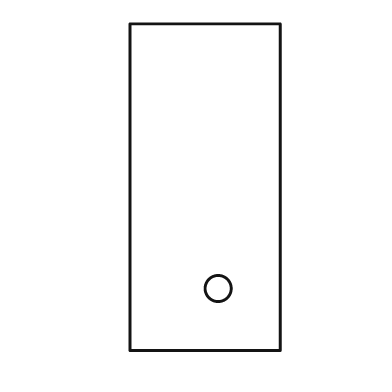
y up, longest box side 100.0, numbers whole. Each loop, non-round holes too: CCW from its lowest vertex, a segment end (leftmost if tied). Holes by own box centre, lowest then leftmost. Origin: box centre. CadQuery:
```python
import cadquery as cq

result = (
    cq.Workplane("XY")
    .moveTo(-23.0, -50.0)
    .lineTo(23.0, -50.0)
    .lineTo(23.0, 50.0)
    .lineTo(-23.0, 50.0)
    .close()
    .moveTo(4.0, -31.0)
    .circle(4.0)
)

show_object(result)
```